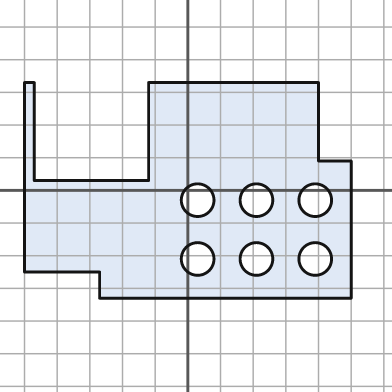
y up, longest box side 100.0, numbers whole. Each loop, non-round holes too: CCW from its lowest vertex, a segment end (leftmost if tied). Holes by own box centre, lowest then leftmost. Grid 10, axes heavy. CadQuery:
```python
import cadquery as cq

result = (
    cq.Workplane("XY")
    .moveTo(-27.0, -33.0)
    .lineTo(50.0, -33.0)
    .lineTo(50.0, 9.0)
    .lineTo(40.0, 9.0)
    .lineTo(40.0, 33.0)
    .lineTo(-12.0, 33.0)
    .lineTo(-12.0, 3.0)
    .lineTo(-47.0, 3.0)
    .lineTo(-47.0, 33.0)
    .lineTo(-50.0, 33.0)
    .lineTo(-50.0, -25.0)
    .lineTo(-27.0, -25.0)
    .close()
    .moveTo(3.0, -21.0)
    .circle(5.0)
    .moveTo(21.0, -21.0)
    .circle(5.0)
    .moveTo(39.0, -21.0)
    .circle(5.0)
    .moveTo(3.0, -3.0)
    .circle(5.0)
    .moveTo(21.0, -3.0)
    .circle(5.0)
    .moveTo(39.0, -3.0)
    .circle(5.0)
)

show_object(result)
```